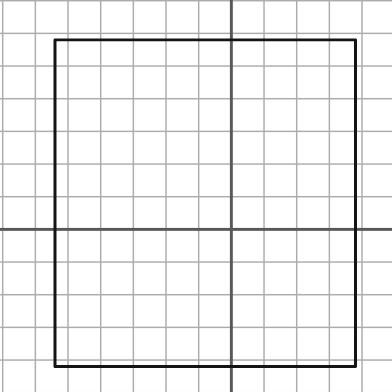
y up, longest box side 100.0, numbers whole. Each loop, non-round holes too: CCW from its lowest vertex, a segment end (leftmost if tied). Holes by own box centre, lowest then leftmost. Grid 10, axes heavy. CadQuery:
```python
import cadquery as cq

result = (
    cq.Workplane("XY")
    .moveTo(-54.0, -42.0)
    .lineTo(38.0, -42.0)
    .lineTo(38.0, 58.0)
    .lineTo(-54.0, 58.0)
    .close()
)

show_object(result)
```